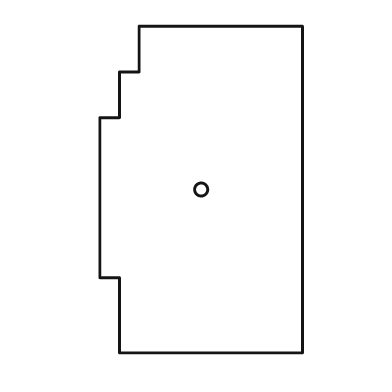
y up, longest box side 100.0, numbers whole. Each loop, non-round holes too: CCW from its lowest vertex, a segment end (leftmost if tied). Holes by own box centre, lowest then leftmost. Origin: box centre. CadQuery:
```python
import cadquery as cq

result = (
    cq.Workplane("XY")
    .moveTo(-25.0, -50.0)
    .lineTo(31.0, -50.0)
    .lineTo(31.0, 50.0)
    .lineTo(-19.0, 50.0)
    .lineTo(-19.0, 36.0)
    .lineTo(-25.0, 36.0)
    .lineTo(-25.0, 22.0)
    .lineTo(-31.0, 22.0)
    .lineTo(-31.0, -27.0)
    .lineTo(-25.0, -27.0)
    .close()
    .moveTo(0.0, 0.0)
    .circle(2.0)
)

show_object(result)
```